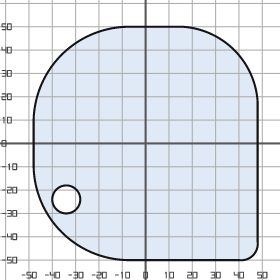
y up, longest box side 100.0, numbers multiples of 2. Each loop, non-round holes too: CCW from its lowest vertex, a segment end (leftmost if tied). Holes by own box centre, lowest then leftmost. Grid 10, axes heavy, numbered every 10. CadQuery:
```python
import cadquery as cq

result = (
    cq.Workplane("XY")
    .moveTo(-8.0, -50.0)
    .lineTo(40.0, -50.0)
    .threePointArc((46.0, -48.0), (48.0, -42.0))
    .lineTo(48.0, 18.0)
    .threePointArc((38.0, 40.0), (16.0, 50.0))
    .lineTo(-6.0, 50.0)
    .threePointArc((-36.0, 38.0), (-48.0, 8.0))
    .lineTo(-48.0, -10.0)
    .threePointArc((-36.0, -38.0), (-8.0, -50.0))
    .close()
    .moveTo(-34.0, -24.0)
    .circle(6.0)
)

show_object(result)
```